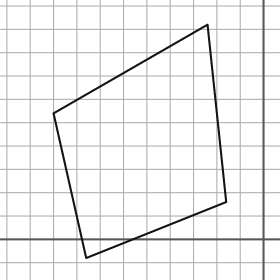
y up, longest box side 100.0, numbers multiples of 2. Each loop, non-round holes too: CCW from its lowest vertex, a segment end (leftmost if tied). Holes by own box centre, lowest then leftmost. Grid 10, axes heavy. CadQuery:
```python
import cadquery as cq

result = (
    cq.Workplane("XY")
    .moveTo(-76.0, -8.0)
    .lineTo(-16.0, 16.0)
    .lineTo(-24.0, 92.0)
    .lineTo(-90.0, 54.0)
    .close()
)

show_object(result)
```